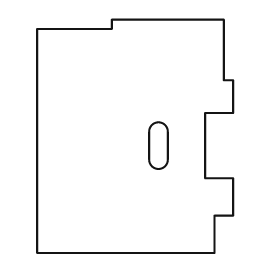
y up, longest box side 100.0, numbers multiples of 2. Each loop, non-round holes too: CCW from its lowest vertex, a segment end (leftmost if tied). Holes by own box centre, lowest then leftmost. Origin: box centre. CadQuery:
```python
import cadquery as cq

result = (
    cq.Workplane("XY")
    .moveTo(-42.0, -50.0)
    .lineTo(34.0, -50.0)
    .lineTo(34.0, -34.0)
    .lineTo(42.0, -34.0)
    .lineTo(42.0, -18.0)
    .lineTo(30.0, -18.0)
    .lineTo(30.0, 10.0)
    .lineTo(42.0, 10.0)
    .lineTo(42.0, 24.0)
    .lineTo(38.0, 24.0)
    .lineTo(38.0, 50.0)
    .lineTo(-10.0, 50.0)
    .lineTo(-10.0, 46.0)
    .lineTo(-42.0, 46.0)
    .close()
    .moveTo(6.0, -10.0)
    .threePointArc((10.0, -14.0), (14.0, -10.0))
    .lineTo(14.0, 2.0)
    .threePointArc((10.0, 6.0), (6.0, 2.0))
    .close()
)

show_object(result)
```